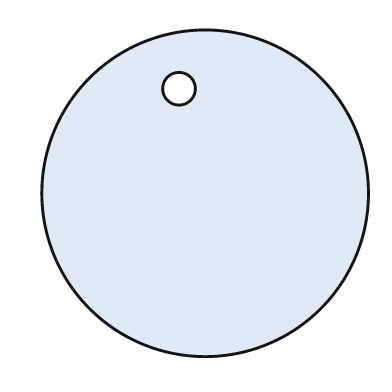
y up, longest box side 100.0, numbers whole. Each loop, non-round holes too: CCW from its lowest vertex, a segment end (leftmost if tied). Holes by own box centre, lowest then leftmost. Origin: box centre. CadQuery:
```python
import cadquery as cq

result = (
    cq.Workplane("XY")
    .moveTo(0.0, 0.0)
    .circle(50.0)
    .moveTo(-8.0, 32.0)
    .circle(5.0)
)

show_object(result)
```